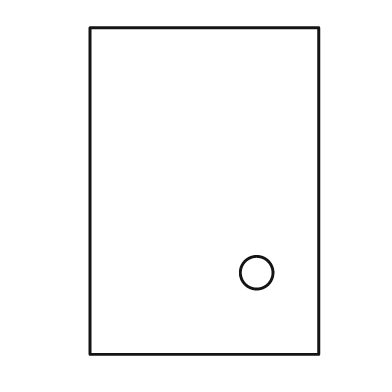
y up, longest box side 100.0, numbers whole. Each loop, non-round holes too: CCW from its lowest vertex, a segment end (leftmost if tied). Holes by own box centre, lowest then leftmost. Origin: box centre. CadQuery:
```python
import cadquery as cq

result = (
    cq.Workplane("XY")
    .moveTo(-35.0, -50.0)
    .lineTo(35.0, -50.0)
    .lineTo(35.0, 50.0)
    .lineTo(-35.0, 50.0)
    .close()
    .moveTo(16.0, -25.0)
    .circle(5.0)
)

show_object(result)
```